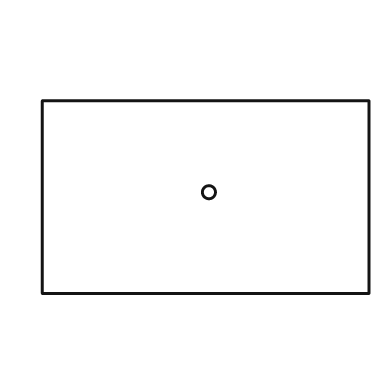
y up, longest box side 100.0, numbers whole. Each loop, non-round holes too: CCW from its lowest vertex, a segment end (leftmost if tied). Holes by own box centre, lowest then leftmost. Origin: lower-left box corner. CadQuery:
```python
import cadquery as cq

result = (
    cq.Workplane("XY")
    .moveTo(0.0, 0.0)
    .lineTo(100.0, 0.0)
    .lineTo(100.0, 59.0)
    .lineTo(0.0, 59.0)
    .close()
    .moveTo(51.0, 31.0)
    .circle(2.0)
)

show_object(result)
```